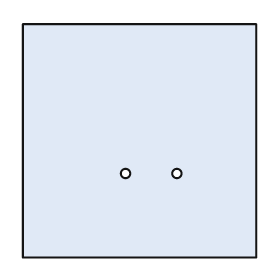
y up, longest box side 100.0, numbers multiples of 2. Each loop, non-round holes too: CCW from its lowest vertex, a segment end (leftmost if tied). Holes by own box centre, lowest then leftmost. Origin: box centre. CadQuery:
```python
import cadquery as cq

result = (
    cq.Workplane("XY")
    .moveTo(-50.0, -50.0)
    .lineTo(50.0, -50.0)
    .lineTo(50.0, 50.0)
    .lineTo(-50.0, 50.0)
    .close()
    .moveTo(-6.0, -14.0)
    .circle(2.0)
    .moveTo(16.0, -14.0)
    .circle(2.0)
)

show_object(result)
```